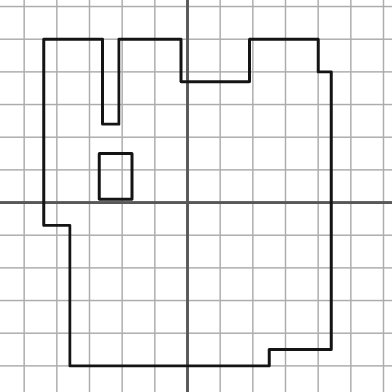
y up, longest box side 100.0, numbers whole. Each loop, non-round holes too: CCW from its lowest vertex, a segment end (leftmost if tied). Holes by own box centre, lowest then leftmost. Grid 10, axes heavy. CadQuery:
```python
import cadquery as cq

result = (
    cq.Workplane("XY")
    .moveTo(-36.0, -50.0)
    .lineTo(25.0, -50.0)
    .lineTo(25.0, -45.0)
    .lineTo(44.0, -45.0)
    .lineTo(44.0, 40.0)
    .lineTo(40.0, 40.0)
    .lineTo(40.0, 50.0)
    .lineTo(19.0, 50.0)
    .lineTo(19.0, 37.0)
    .lineTo(-2.0, 37.0)
    .lineTo(-2.0, 50.0)
    .lineTo(-21.0, 50.0)
    .lineTo(-21.0, 24.0)
    .lineTo(-26.0, 24.0)
    .lineTo(-26.0, 50.0)
    .lineTo(-44.0, 50.0)
    .lineTo(-44.0, -7.0)
    .lineTo(-36.0, -7.0)
    .close()
    .moveTo(-27.0, 1.0)
    .lineTo(-17.0, 1.0)
    .lineTo(-17.0, 15.0)
    .lineTo(-27.0, 15.0)
    .close()
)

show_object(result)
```